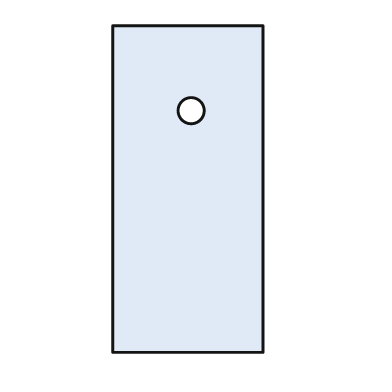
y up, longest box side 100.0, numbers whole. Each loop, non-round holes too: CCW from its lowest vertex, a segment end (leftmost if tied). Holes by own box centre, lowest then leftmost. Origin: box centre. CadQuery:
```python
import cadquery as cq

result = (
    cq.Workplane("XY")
    .moveTo(-23.0, -50.0)
    .lineTo(23.0, -50.0)
    .lineTo(23.0, 50.0)
    .lineTo(-23.0, 50.0)
    .close()
    .moveTo(1.0, 24.0)
    .circle(4.0)
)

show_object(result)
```